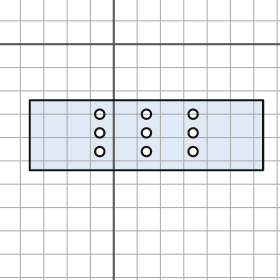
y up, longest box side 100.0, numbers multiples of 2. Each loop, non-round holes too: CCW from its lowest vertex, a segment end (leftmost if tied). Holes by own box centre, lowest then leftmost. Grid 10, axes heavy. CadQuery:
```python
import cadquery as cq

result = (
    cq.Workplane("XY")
    .moveTo(-36.0, -54.0)
    .lineTo(64.0, -54.0)
    .lineTo(64.0, -24.0)
    .lineTo(-36.0, -24.0)
    .close()
    .moveTo(-6.0, -46.0)
    .circle(2.0)
    .moveTo(14.0, -46.0)
    .circle(2.0)
    .moveTo(34.0, -46.0)
    .circle(2.0)
    .moveTo(-6.0, -38.0)
    .circle(2.0)
    .moveTo(14.0, -38.0)
    .circle(2.0)
    .moveTo(34.0, -38.0)
    .circle(2.0)
    .moveTo(-6.0, -30.0)
    .circle(2.0)
    .moveTo(14.0, -30.0)
    .circle(2.0)
    .moveTo(34.0, -30.0)
    .circle(2.0)
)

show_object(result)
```